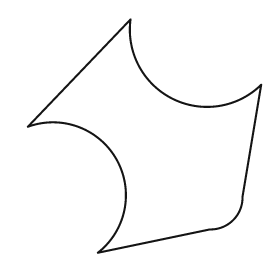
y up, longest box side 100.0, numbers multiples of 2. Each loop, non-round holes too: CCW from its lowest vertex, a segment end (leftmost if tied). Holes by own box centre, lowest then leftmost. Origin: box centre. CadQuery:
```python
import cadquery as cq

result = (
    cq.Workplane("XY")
    .moveTo(-20.0, -50.0)
    .lineTo(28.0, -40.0)
    .threePointArc((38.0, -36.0), (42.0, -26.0))
    .lineTo(50.0, 22.0)
    .threePointArc((12.0, 16.0), (-6.0, 50.0))
    .lineTo(-50.0, 4.0)
    .threePointArc((-12.0, -10.0), (-20.0, -50.0))
    .close()
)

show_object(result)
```